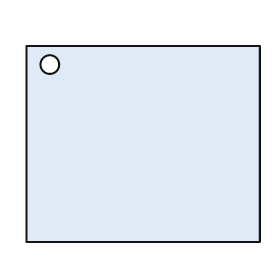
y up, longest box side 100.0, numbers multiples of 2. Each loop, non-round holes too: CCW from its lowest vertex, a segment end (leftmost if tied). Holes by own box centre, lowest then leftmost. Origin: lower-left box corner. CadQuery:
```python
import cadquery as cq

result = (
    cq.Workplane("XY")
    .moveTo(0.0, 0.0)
    .lineTo(100.0, 0.0)
    .lineTo(100.0, 84.0)
    .lineTo(0.0, 84.0)
    .close()
    .moveTo(10.0, 76.0)
    .circle(4.0)
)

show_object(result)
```